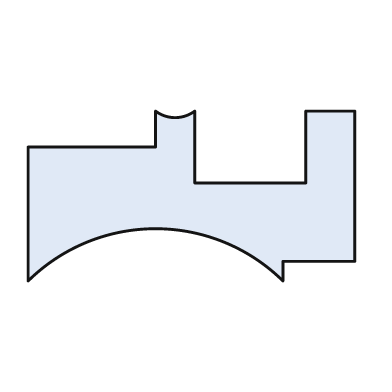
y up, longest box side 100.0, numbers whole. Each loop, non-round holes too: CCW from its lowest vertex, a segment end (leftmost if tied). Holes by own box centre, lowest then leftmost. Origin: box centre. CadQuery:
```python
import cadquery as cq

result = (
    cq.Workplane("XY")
    .moveTo(-50.0, -26.0)
    .threePointArc((-11.0, -10.0), (28.0, -26.0))
    .lineTo(28.0, -20.0)
    .lineTo(50.0, -20.0)
    .lineTo(50.0, 26.0)
    .lineTo(35.0, 26.0)
    .lineTo(35.0, 4.0)
    .lineTo(1.0, 4.0)
    .lineTo(1.0, 26.0)
    .threePointArc((-5.0, 24.0), (-11.0, 26.0))
    .lineTo(-11.0, 15.0)
    .lineTo(-50.0, 15.0)
    .close()
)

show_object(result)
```